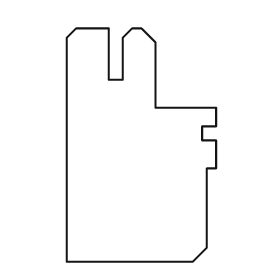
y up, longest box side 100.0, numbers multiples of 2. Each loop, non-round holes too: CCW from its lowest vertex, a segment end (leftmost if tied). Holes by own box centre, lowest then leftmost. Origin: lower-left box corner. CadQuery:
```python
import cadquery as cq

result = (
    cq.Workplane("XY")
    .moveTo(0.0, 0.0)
    .lineTo(54.0, 0.0)
    .lineTo(60.0, 6.0)
    .lineTo(60.0, 40.0)
    .lineTo(64.0, 40.0)
    .lineTo(64.0, 52.0)
    .lineTo(58.0, 52.0)
    .lineTo(58.0, 58.0)
    .lineTo(64.0, 58.0)
    .lineTo(64.0, 66.0)
    .lineTo(38.0, 66.0)
    .lineTo(38.0, 94.0)
    .lineTo(32.0, 100.0)
    .lineTo(28.0, 100.0)
    .lineTo(24.0, 96.0)
    .lineTo(24.0, 78.0)
    .lineTo(18.0, 78.0)
    .lineTo(18.0, 100.0)
    .lineTo(4.0, 100.0)
    .lineTo(0.0, 96.0)
    .close()
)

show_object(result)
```